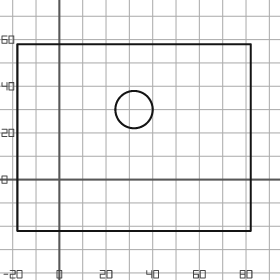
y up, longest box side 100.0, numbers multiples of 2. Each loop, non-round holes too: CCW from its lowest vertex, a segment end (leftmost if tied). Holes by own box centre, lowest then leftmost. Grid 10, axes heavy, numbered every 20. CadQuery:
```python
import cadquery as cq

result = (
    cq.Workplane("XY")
    .moveTo(-18.0, -22.0)
    .lineTo(82.0, -22.0)
    .lineTo(82.0, 58.0)
    .lineTo(-18.0, 58.0)
    .close()
    .moveTo(32.0, 30.0)
    .circle(8.0)
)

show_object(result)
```